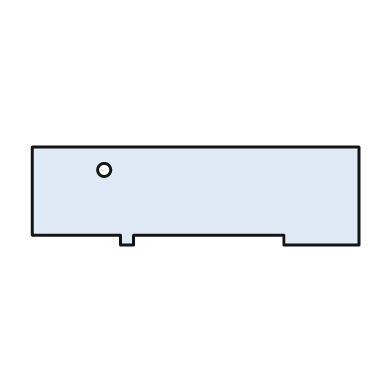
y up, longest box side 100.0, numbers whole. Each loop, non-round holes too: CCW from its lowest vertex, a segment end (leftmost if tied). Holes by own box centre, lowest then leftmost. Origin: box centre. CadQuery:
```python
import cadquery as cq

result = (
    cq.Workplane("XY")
    .moveTo(-23.0, -15.0)
    .lineTo(-19.0, -15.0)
    .lineTo(-19.0, -12.0)
    .lineTo(27.0, -12.0)
    .lineTo(27.0, -15.0)
    .lineTo(50.0, -15.0)
    .lineTo(50.0, 15.0)
    .lineTo(-50.0, 15.0)
    .lineTo(-50.0, -12.0)
    .lineTo(-23.0, -12.0)
    .close()
    .moveTo(-28.0, 8.0)
    .circle(2.0)
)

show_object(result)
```